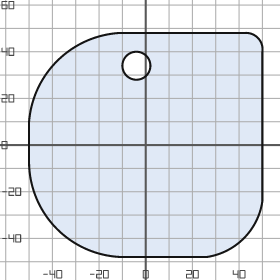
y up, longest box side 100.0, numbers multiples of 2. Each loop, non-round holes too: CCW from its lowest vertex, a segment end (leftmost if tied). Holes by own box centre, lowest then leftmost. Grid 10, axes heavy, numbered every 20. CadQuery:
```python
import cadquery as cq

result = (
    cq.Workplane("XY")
    .moveTo(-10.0, -48.0)
    .lineTo(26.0, -48.0)
    .threePointArc((42.0, -40.0), (50.0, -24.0))
    .lineTo(50.0, 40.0)
    .threePointArc((48.0, 46.0), (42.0, 48.0))
    .lineTo(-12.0, 48.0)
    .threePointArc((-38.0, 36.0), (-50.0, 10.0))
    .lineTo(-50.0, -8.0)
    .threePointArc((-38.0, -36.0), (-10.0, -48.0))
    .close()
    .moveTo(-4.0, 34.0)
    .circle(6.0)
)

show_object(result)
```